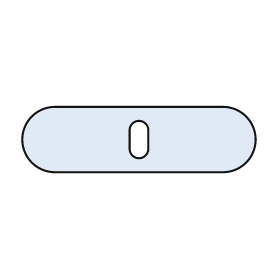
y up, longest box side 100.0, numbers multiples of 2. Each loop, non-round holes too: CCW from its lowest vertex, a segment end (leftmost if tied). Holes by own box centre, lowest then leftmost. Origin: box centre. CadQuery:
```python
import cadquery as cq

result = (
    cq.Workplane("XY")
    .moveTo(-36.0, -14.0)
    .lineTo(36.0, -14.0)
    .threePointArc((50.0, 0.0), (36.0, 14.0))
    .lineTo(-36.0, 14.0)
    .threePointArc((-50.0, 0.0), (-36.0, -14.0))
    .close()
    .moveTo(-4.0, -4.0)
    .threePointArc((0.0, -8.0), (4.0, -4.0))
    .lineTo(4.0, 4.0)
    .threePointArc((0.0, 8.0), (-4.0, 4.0))
    .close()
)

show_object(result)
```